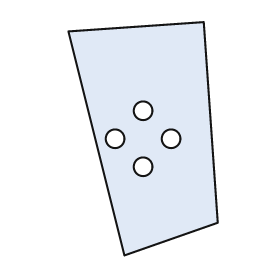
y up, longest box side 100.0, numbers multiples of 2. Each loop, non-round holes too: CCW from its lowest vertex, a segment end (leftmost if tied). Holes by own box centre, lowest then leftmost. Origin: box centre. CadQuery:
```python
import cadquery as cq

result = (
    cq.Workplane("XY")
    .moveTo(-8.0, -50.0)
    .lineTo(32.0, -36.0)
    .lineTo(26.0, 50.0)
    .lineTo(-32.0, 46.0)
    .close()
    .moveTo(0.0, -12.0)
    .circle(4.0)
    .moveTo(-12.0, 0.0)
    .circle(4.0)
    .moveTo(12.0, 0.0)
    .circle(4.0)
    .moveTo(0.0, 12.0)
    .circle(4.0)
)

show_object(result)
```